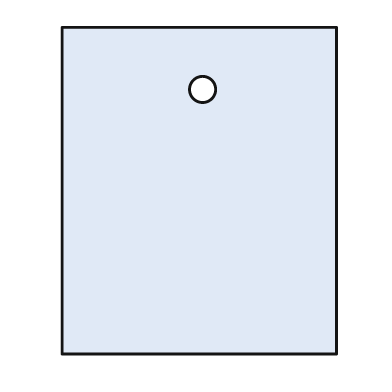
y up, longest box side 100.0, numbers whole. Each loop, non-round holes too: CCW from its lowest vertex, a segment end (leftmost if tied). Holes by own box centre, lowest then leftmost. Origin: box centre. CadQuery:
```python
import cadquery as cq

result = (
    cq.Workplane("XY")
    .moveTo(-42.0, -50.0)
    .lineTo(42.0, -50.0)
    .lineTo(42.0, 50.0)
    .lineTo(-42.0, 50.0)
    .close()
    .moveTo(1.0, 31.0)
    .circle(4.0)
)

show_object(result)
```